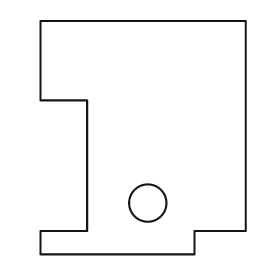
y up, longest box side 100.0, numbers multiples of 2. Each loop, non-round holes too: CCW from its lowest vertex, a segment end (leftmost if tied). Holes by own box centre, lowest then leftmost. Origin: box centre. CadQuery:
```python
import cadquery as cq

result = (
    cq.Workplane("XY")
    .moveTo(-44.0, -50.0)
    .lineTo(22.0, -50.0)
    .lineTo(22.0, -40.0)
    .lineTo(44.0, -40.0)
    .lineTo(44.0, 50.0)
    .lineTo(-44.0, 50.0)
    .lineTo(-44.0, 16.0)
    .lineTo(-24.0, 16.0)
    .lineTo(-24.0, -40.0)
    .lineTo(-44.0, -40.0)
    .close()
    .moveTo(2.0, -28.0)
    .circle(8.0)
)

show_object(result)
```